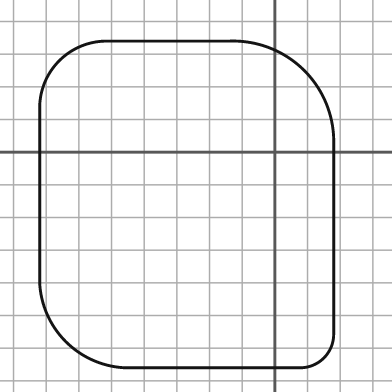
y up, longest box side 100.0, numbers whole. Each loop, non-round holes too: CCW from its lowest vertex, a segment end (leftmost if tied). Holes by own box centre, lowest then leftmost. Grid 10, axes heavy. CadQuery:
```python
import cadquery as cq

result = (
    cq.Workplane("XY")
    .moveTo(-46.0, -66.0)
    .lineTo(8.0, -66.0)
    .threePointArc((15.0, -63.0), (18.0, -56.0))
    .lineTo(18.0, 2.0)
    .threePointArc((9.0, 25.0), (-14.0, 34.0))
    .lineTo(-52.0, 34.0)
    .threePointArc((-66.0, 28.0), (-72.0, 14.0))
    .lineTo(-72.0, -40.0)
    .threePointArc((-64.0, -58.0), (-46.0, -66.0))
    .close()
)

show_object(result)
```